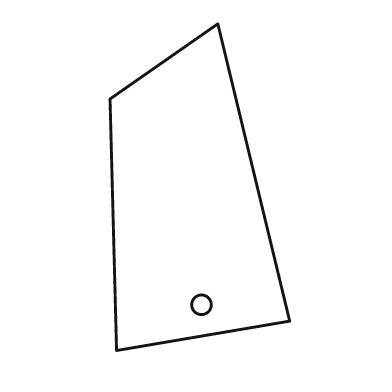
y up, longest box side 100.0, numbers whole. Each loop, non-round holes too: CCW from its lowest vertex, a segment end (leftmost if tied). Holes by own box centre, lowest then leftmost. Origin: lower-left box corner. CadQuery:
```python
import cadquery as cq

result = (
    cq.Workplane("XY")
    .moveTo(2.0, 0.0)
    .lineTo(55.0, 9.0)
    .lineTo(33.0, 100.0)
    .lineTo(0.0, 77.0)
    .close()
    .moveTo(28.0, 14.0)
    .circle(3.0)
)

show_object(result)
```